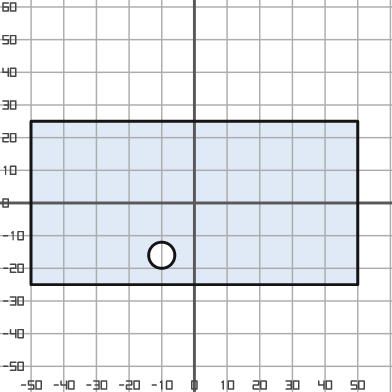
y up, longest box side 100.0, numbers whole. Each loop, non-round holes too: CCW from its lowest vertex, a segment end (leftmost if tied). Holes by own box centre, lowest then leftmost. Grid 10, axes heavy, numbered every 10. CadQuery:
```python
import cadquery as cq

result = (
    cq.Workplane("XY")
    .moveTo(-50.0, -25.0)
    .lineTo(50.0, -25.0)
    .lineTo(50.0, 25.0)
    .lineTo(-50.0, 25.0)
    .close()
    .moveTo(-10.0, -16.0)
    .circle(4.0)
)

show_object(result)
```